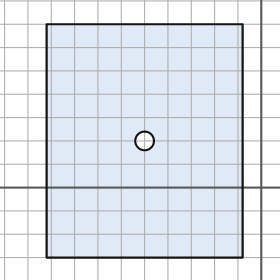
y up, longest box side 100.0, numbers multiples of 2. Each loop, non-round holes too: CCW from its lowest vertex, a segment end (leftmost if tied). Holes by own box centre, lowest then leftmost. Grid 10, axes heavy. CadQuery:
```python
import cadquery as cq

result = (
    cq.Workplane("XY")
    .moveTo(-92.0, -30.0)
    .lineTo(-8.0, -30.0)
    .lineTo(-8.0, 70.0)
    .lineTo(-92.0, 70.0)
    .close()
    .moveTo(-50.0, 20.0)
    .circle(4.0)
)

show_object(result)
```